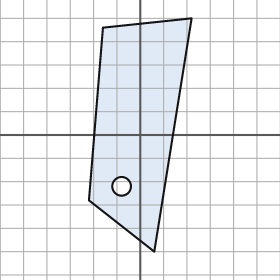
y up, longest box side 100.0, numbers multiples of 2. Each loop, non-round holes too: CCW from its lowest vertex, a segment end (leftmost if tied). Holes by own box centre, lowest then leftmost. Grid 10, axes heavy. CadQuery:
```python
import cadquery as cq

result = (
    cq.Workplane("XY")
    .moveTo(6.0, -50.0)
    .lineTo(22.0, 50.0)
    .lineTo(-16.0, 46.0)
    .lineTo(-22.0, -28.0)
    .close()
    .moveTo(-8.0, -22.0)
    .circle(4.0)
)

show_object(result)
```